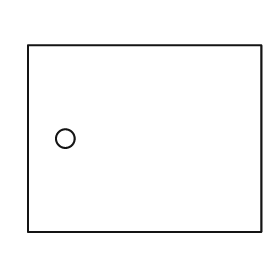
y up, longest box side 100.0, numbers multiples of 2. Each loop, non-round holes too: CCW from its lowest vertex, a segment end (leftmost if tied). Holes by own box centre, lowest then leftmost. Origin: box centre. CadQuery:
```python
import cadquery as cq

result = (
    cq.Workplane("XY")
    .moveTo(-50.0, -40.0)
    .lineTo(50.0, -40.0)
    .lineTo(50.0, 40.0)
    .lineTo(-50.0, 40.0)
    .close()
    .moveTo(-34.0, 0.0)
    .circle(4.0)
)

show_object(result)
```